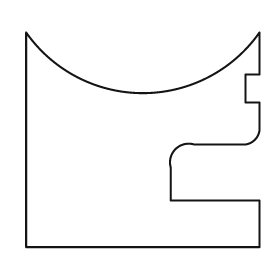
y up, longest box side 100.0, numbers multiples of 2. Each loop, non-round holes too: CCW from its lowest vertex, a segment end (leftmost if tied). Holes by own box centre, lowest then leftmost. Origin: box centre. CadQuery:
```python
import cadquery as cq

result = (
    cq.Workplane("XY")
    .moveTo(-50.0, -46.0)
    .lineTo(50.0, -46.0)
    .lineTo(50.0, -26.0)
    .lineTo(12.0, -26.0)
    .lineTo(12.0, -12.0)
    .threePointArc((14.0, -4.0), (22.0, -2.0))
    .lineTo(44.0, -2.0)
    .threePointArc((48.0, 0.0), (50.0, 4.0))
    .lineTo(50.0, 16.0)
    .lineTo(44.0, 16.0)
    .lineTo(44.0, 28.0)
    .lineTo(50.0, 28.0)
    .lineTo(50.0, 46.0)
    .threePointArc((0.0, 20.0), (-50.0, 46.0))
    .close()
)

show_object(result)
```